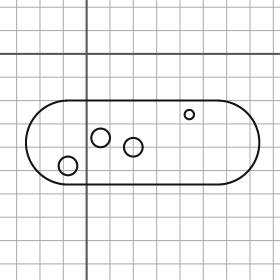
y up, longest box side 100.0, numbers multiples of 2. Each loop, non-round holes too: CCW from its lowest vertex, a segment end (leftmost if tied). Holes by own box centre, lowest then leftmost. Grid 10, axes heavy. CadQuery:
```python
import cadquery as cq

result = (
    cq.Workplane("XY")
    .moveTo(-8.0, -56.0)
    .lineTo(56.0, -56.0)
    .threePointArc((74.0, -38.0), (56.0, -20.0))
    .lineTo(-8.0, -20.0)
    .threePointArc((-26.0, -38.0), (-8.0, -56.0))
    .close()
    .moveTo(-8.0, -48.0)
    .circle(4.0)
    .moveTo(20.0, -40.0)
    .circle(4.0)
    .moveTo(6.0, -36.0)
    .circle(4.0)
    .moveTo(44.0, -26.0)
    .circle(2.0)
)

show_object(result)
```